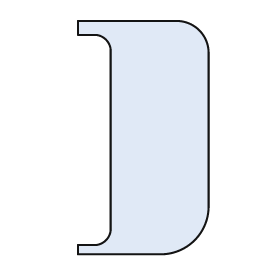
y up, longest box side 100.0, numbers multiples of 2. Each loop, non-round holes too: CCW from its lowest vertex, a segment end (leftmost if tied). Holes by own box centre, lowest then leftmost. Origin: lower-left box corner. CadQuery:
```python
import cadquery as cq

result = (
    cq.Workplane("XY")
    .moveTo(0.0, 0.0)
    .lineTo(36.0, 0.0)
    .threePointArc((50.0, 6.0), (56.0, 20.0))
    .lineTo(56.0, 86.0)
    .threePointArc((52.0, 96.0), (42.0, 100.0))
    .lineTo(0.0, 100.0)
    .lineTo(0.0, 94.0)
    .lineTo(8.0, 94.0)
    .threePointArc((12.0, 92.0), (14.0, 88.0))
    .lineTo(14.0, 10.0)
    .threePointArc((12.0, 6.0), (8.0, 4.0))
    .lineTo(0.0, 4.0)
    .close()
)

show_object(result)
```